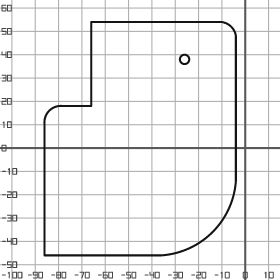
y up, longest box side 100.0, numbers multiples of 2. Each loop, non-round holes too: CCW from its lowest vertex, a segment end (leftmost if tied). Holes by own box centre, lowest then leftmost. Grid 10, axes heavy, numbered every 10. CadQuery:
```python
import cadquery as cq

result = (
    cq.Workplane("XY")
    .moveTo(-86.0, -46.0)
    .lineTo(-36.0, -46.0)
    .threePointArc((-14.0, -36.0), (-4.0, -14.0))
    .lineTo(-4.0, 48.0)
    .threePointArc((-6.0, 52.0), (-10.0, 54.0))
    .lineTo(-66.0, 54.0)
    .lineTo(-66.0, 18.0)
    .lineTo(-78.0, 18.0)
    .threePointArc((-84.0, 16.0), (-86.0, 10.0))
    .close()
    .moveTo(-26.0, 38.0)
    .circle(2.0)
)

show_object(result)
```